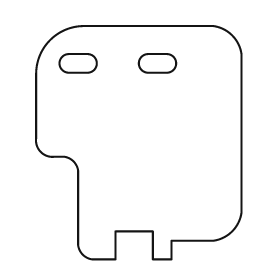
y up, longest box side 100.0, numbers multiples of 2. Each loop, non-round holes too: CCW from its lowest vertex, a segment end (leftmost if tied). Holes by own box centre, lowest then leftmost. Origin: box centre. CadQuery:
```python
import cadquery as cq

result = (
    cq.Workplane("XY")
    .moveTo(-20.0, -50.0)
    .lineTo(-10.0, -50.0)
    .lineTo(-10.0, -38.0)
    .lineTo(6.0, -38.0)
    .lineTo(6.0, -50.0)
    .lineTo(14.0, -50.0)
    .lineTo(14.0, -42.0)
    .lineTo(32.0, -42.0)
    .threePointArc((40.0, -38.0), (44.0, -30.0))
    .lineTo(44.0, 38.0)
    .threePointArc((40.0, 46.0), (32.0, 50.0))
    .lineTo(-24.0, 50.0)
    .threePointArc((-38.0, 44.0), (-44.0, 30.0))
    .lineTo(-44.0, 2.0)
    .threePointArc((-42.0, -4.0), (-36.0, -6.0))
    .lineTo(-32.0, -6.0)
    .threePointArc((-28.0, -8.0), (-26.0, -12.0))
    .lineTo(-26.0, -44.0)
    .threePointArc((-24.0, -48.0), (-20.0, -50.0))
    .close()
    .moveTo(-30.0, 30.0)
    .lineTo(-22.0, 30.0)
    .threePointArc((-18.0, 34.0), (-22.0, 38.0))
    .lineTo(-30.0, 38.0)
    .threePointArc((-34.0, 34.0), (-30.0, 30.0))
    .close()
    .moveTo(4.0, 30.0)
    .lineTo(12.0, 30.0)
    .threePointArc((16.0, 34.0), (12.0, 38.0))
    .lineTo(4.0, 38.0)
    .threePointArc((0.0, 34.0), (4.0, 30.0))
    .close()
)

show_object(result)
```